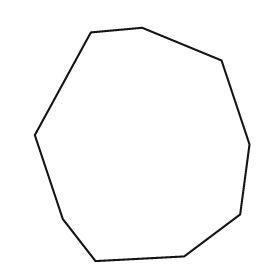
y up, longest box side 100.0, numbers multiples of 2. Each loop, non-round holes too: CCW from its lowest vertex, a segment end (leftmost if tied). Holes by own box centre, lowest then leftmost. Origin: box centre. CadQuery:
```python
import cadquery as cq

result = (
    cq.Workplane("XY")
    .moveTo(-20.0, -50.0)
    .lineTo(18.0, -48.0)
    .lineTo(42.0, -30.0)
    .lineTo(46.0, 0.0)
    .lineTo(34.0, 36.0)
    .lineTo(0.0, 50.0)
    .lineTo(-22.0, 48.0)
    .lineTo(-46.0, 4.0)
    .lineTo(-34.0, -32.0)
    .close()
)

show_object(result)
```